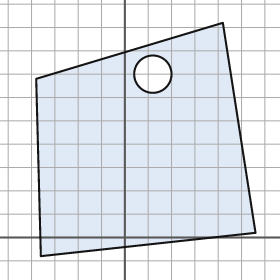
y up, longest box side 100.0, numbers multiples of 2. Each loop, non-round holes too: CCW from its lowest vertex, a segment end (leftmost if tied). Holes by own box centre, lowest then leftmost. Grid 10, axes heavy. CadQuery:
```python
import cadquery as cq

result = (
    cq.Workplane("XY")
    .moveTo(-36.0, -8.0)
    .lineTo(56.0, 2.0)
    .lineTo(42.0, 92.0)
    .lineTo(-38.0, 68.0)
    .close()
    .moveTo(12.0, 70.0)
    .circle(8.0)
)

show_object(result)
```